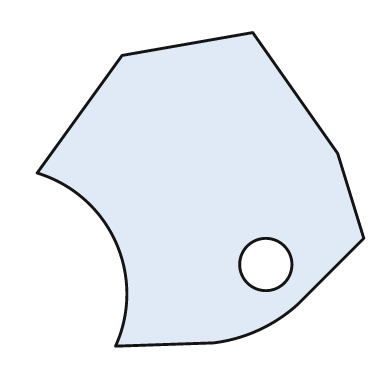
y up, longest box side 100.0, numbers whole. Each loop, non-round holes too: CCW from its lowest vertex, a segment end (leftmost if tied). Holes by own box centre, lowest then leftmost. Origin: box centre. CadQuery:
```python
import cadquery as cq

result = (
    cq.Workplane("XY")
    .moveTo(-26.0, -48.0)
    .lineTo(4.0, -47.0)
    .threePointArc((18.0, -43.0), (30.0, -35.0))
    .lineTo(50.0, -15.0)
    .lineTo(42.0, 11.0)
    .lineTo(16.0, 48.0)
    .lineTo(-24.0, 41.0)
    .lineTo(-50.0, 5.0)
    .threePointArc((-26.0, -16.0), (-26.0, -48.0))
    .close()
    .moveTo(20.0, -23.0)
    .circle(8.0)
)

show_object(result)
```